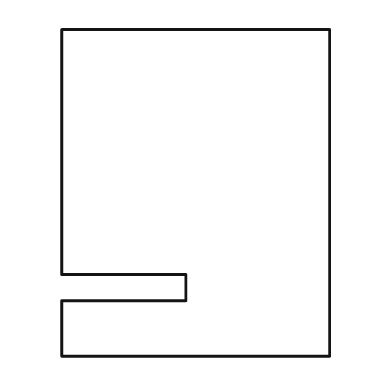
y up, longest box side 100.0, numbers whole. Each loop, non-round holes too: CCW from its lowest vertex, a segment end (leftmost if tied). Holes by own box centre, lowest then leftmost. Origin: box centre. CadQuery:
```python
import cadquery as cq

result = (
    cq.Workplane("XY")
    .moveTo(-41.0, -50.0)
    .lineTo(41.0, -50.0)
    .lineTo(41.0, 50.0)
    .lineTo(-41.0, 50.0)
    .lineTo(-41.0, -25.0)
    .lineTo(-3.0, -25.0)
    .lineTo(-3.0, -33.0)
    .lineTo(-41.0, -33.0)
    .close()
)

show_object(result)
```